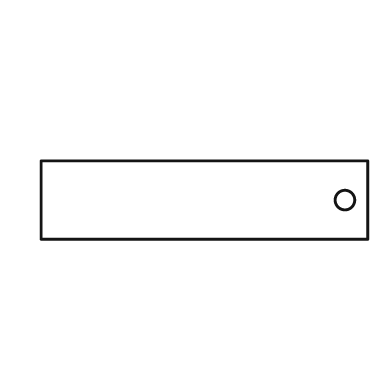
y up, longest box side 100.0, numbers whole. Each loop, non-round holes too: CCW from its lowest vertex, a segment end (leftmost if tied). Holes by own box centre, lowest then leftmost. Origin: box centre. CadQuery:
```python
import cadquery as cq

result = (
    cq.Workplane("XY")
    .moveTo(-50.0, -12.0)
    .lineTo(50.0, -12.0)
    .lineTo(50.0, 12.0)
    .lineTo(-50.0, 12.0)
    .close()
    .moveTo(43.0, 0.0)
    .circle(3.0)
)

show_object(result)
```